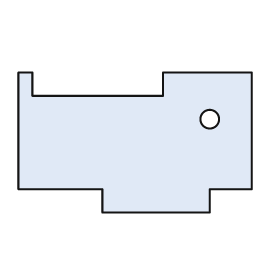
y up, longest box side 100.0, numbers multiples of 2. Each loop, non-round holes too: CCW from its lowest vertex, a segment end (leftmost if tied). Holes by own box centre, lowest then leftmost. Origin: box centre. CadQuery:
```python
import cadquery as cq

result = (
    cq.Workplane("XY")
    .moveTo(-14.0, -30.0)
    .lineTo(32.0, -30.0)
    .lineTo(32.0, -20.0)
    .lineTo(50.0, -20.0)
    .lineTo(50.0, 30.0)
    .lineTo(12.0, 30.0)
    .lineTo(12.0, 20.0)
    .lineTo(-44.0, 20.0)
    .lineTo(-44.0, 30.0)
    .lineTo(-50.0, 30.0)
    .lineTo(-50.0, -20.0)
    .lineTo(-14.0, -20.0)
    .close()
    .moveTo(32.0, 10.0)
    .circle(4.0)
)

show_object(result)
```